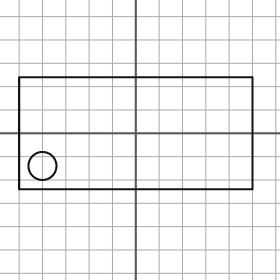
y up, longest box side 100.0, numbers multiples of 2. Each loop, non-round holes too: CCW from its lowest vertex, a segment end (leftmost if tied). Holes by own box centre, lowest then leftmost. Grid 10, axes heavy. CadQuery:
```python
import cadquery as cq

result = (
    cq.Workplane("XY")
    .moveTo(-50.0, -24.0)
    .lineTo(50.0, -24.0)
    .lineTo(50.0, 24.0)
    .lineTo(-50.0, 24.0)
    .close()
    .moveTo(-40.0, -14.0)
    .circle(6.0)
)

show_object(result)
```